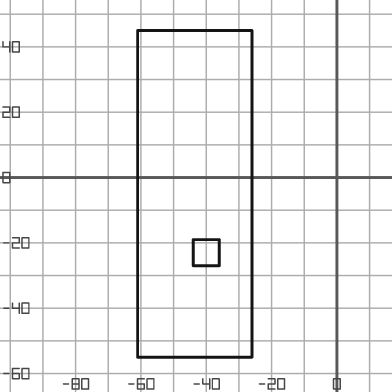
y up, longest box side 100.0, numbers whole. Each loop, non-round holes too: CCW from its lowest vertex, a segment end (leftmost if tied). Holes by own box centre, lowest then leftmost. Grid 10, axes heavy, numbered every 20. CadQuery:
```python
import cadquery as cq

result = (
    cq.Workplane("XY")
    .moveTo(-61.0, -55.0)
    .lineTo(-26.0, -55.0)
    .lineTo(-26.0, 45.0)
    .lineTo(-61.0, 45.0)
    .close()
    .moveTo(-44.0, -27.0)
    .lineTo(-36.0, -27.0)
    .lineTo(-36.0, -19.0)
    .lineTo(-44.0, -19.0)
    .close()
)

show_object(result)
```